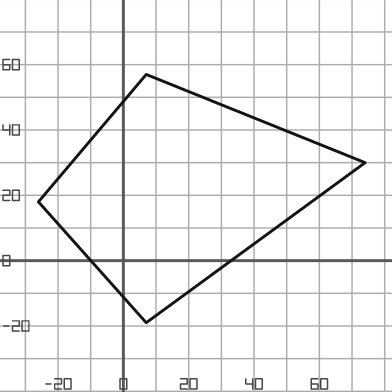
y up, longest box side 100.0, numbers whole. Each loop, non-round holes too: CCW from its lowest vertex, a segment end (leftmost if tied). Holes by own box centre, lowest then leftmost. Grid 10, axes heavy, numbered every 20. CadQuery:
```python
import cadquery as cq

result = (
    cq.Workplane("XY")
    .moveTo(7.0, -19.0)
    .lineTo(74.0, 30.0)
    .lineTo(7.0, 57.0)
    .lineTo(-26.0, 18.0)
    .close()
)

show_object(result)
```